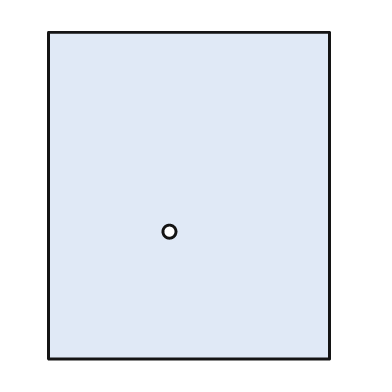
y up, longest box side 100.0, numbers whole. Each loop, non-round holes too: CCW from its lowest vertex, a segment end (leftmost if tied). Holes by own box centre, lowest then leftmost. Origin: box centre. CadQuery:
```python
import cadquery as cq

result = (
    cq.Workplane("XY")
    .moveTo(-43.0, -50.0)
    .lineTo(43.0, -50.0)
    .lineTo(43.0, 50.0)
    .lineTo(-43.0, 50.0)
    .close()
    .moveTo(-6.0, -11.0)
    .circle(2.0)
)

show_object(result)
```